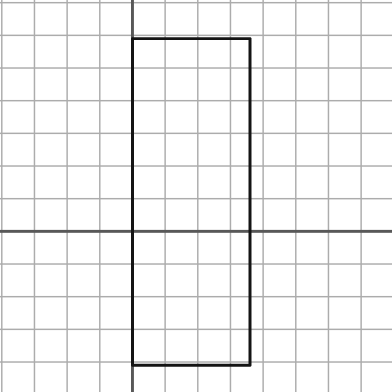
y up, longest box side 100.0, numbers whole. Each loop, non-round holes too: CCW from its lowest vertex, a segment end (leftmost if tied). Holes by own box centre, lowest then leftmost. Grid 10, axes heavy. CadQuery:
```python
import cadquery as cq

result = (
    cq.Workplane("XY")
    .moveTo(0.0, -41.0)
    .lineTo(36.0, -41.0)
    .lineTo(36.0, 59.0)
    .lineTo(0.0, 59.0)
    .close()
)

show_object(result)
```